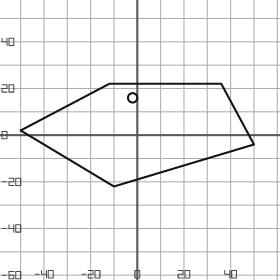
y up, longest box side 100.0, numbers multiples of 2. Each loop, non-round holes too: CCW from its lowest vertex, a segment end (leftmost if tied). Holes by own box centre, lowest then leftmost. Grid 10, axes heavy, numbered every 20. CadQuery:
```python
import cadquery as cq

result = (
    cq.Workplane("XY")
    .moveTo(-10.0, -22.0)
    .lineTo(50.0, -4.0)
    .lineTo(36.0, 22.0)
    .lineTo(-12.0, 22.0)
    .lineTo(-50.0, 2.0)
    .close()
    .moveTo(-2.0, 16.0)
    .circle(2.0)
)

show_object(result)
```